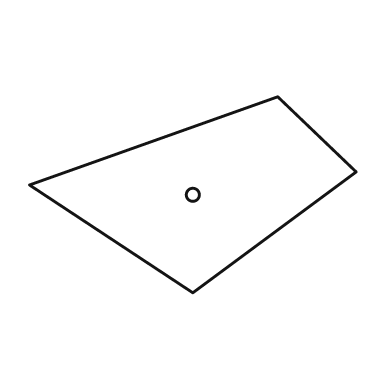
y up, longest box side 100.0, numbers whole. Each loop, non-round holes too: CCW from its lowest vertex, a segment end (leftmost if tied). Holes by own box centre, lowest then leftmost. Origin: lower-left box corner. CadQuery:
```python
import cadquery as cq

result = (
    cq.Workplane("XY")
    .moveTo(50.0, 0.0)
    .lineTo(100.0, 37.0)
    .lineTo(76.0, 60.0)
    .lineTo(0.0, 33.0)
    .close()
    .moveTo(50.0, 30.0)
    .circle(2.0)
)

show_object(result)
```